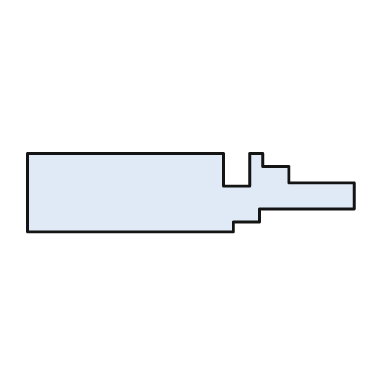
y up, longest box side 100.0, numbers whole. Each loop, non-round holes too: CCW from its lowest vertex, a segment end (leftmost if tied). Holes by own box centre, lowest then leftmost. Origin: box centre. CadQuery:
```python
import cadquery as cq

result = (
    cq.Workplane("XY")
    .moveTo(-50.0, -12.0)
    .lineTo(13.0, -12.0)
    .lineTo(13.0, -9.0)
    .lineTo(21.0, -9.0)
    .lineTo(21.0, -5.0)
    .lineTo(50.0, -5.0)
    .lineTo(50.0, 3.0)
    .lineTo(30.0, 3.0)
    .lineTo(30.0, 8.0)
    .lineTo(22.0, 8.0)
    .lineTo(22.0, 12.0)
    .lineTo(18.0, 12.0)
    .lineTo(18.0, 2.0)
    .lineTo(10.0, 2.0)
    .lineTo(10.0, 12.0)
    .lineTo(-50.0, 12.0)
    .close()
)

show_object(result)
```